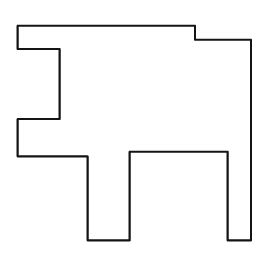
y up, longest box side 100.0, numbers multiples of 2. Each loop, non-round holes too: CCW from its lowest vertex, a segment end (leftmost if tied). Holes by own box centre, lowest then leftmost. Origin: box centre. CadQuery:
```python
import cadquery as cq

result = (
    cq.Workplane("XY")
    .moveTo(-20.0, -46.0)
    .lineTo(-2.0, -46.0)
    .lineTo(-2.0, -8.0)
    .lineTo(40.0, -8.0)
    .lineTo(40.0, -46.0)
    .lineTo(50.0, -46.0)
    .lineTo(50.0, 40.0)
    .lineTo(26.0, 40.0)
    .lineTo(26.0, 46.0)
    .lineTo(-50.0, 46.0)
    .lineTo(-50.0, 36.0)
    .lineTo(-32.0, 36.0)
    .lineTo(-32.0, 6.0)
    .lineTo(-50.0, 6.0)
    .lineTo(-50.0, -10.0)
    .lineTo(-20.0, -10.0)
    .close()
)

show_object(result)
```